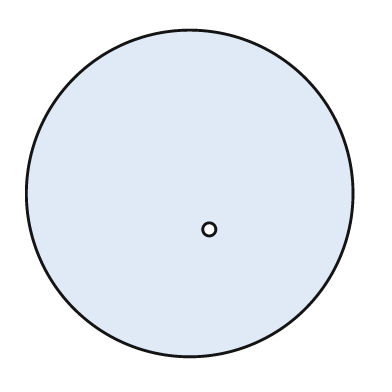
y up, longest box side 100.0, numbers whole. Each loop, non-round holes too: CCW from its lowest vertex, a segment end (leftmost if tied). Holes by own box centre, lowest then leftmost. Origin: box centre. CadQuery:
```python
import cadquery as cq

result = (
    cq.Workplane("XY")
    .moveTo(0.0, 0.0)
    .circle(50.0)
    .moveTo(6.0, -11.0)
    .circle(2.0)
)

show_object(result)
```